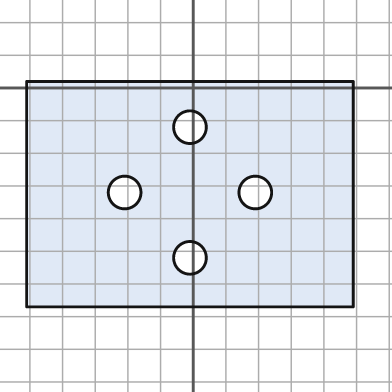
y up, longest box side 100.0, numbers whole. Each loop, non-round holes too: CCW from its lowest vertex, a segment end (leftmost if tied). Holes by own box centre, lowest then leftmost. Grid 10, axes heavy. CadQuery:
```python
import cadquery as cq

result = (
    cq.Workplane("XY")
    .moveTo(-51.0, -67.0)
    .lineTo(49.0, -67.0)
    .lineTo(49.0, 2.0)
    .lineTo(-51.0, 2.0)
    .close()
    .moveTo(-1.0, -52.0)
    .circle(5.0)
    .moveTo(-21.0, -32.0)
    .circle(5.0)
    .moveTo(19.0, -32.0)
    .circle(5.0)
    .moveTo(-1.0, -12.0)
    .circle(5.0)
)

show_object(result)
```